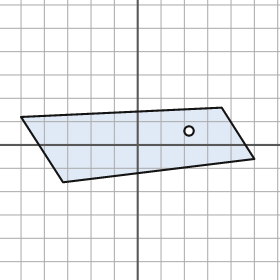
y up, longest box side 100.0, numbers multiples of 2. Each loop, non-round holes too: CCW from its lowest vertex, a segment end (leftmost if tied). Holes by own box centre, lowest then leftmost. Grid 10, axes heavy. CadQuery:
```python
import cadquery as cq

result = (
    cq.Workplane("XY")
    .moveTo(-32.0, -16.0)
    .lineTo(50.0, -6.0)
    .lineTo(36.0, 16.0)
    .lineTo(-50.0, 12.0)
    .close()
    .moveTo(22.0, 6.0)
    .circle(2.0)
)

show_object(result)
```